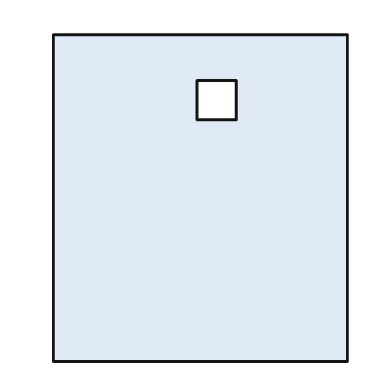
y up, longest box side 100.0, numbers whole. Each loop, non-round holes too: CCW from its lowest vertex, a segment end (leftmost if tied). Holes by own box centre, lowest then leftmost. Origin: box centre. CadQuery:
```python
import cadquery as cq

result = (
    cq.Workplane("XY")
    .moveTo(-45.0, -50.0)
    .lineTo(45.0, -50.0)
    .lineTo(45.0, 50.0)
    .lineTo(-45.0, 50.0)
    .close()
    .moveTo(-1.0, 24.0)
    .lineTo(11.0, 24.0)
    .lineTo(11.0, 36.0)
    .lineTo(-1.0, 36.0)
    .close()
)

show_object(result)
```